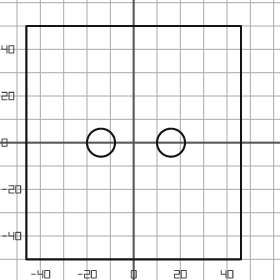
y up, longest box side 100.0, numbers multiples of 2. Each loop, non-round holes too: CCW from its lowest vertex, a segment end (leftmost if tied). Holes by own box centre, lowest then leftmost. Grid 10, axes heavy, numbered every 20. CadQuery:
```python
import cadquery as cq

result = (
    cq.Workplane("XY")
    .moveTo(-46.0, -50.0)
    .lineTo(46.0, -50.0)
    .lineTo(46.0, 50.0)
    .lineTo(-46.0, 50.0)
    .close()
    .moveTo(-14.0, 0.0)
    .circle(6.0)
    .moveTo(16.0, 0.0)
    .circle(6.0)
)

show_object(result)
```